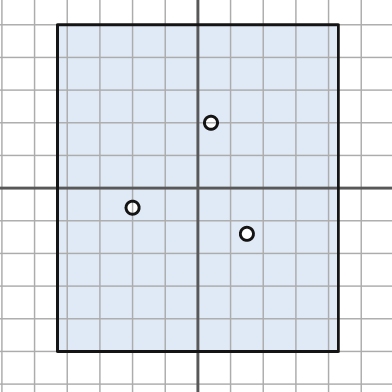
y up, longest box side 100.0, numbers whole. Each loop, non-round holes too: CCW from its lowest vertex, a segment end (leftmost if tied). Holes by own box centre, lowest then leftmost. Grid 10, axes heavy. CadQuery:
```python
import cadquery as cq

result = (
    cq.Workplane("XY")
    .moveTo(-43.0, -50.0)
    .lineTo(43.0, -50.0)
    .lineTo(43.0, 50.0)
    .lineTo(-43.0, 50.0)
    .close()
    .moveTo(15.0, -14.0)
    .circle(2.0)
    .moveTo(-20.0, -6.0)
    .circle(2.0)
    .moveTo(4.0, 20.0)
    .circle(2.0)
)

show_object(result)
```